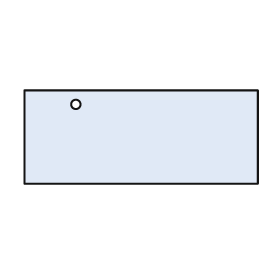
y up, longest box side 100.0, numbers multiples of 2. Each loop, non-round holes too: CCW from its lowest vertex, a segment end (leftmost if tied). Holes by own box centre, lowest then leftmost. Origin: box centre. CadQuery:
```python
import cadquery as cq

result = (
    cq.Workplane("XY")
    .moveTo(-50.0, -20.0)
    .lineTo(50.0, -20.0)
    .lineTo(50.0, 20.0)
    .lineTo(-50.0, 20.0)
    .close()
    .moveTo(-28.0, 14.0)
    .circle(2.0)
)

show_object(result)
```